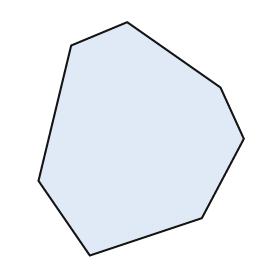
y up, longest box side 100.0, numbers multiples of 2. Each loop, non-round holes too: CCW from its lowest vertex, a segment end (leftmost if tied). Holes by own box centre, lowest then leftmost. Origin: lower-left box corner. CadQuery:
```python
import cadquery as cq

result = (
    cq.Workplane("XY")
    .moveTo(22.0, 0.0)
    .lineTo(70.0, 16.0)
    .lineTo(88.0, 50.0)
    .lineTo(78.0, 72.0)
    .lineTo(38.0, 100.0)
    .lineTo(14.0, 90.0)
    .lineTo(0.0, 32.0)
    .close()
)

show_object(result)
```